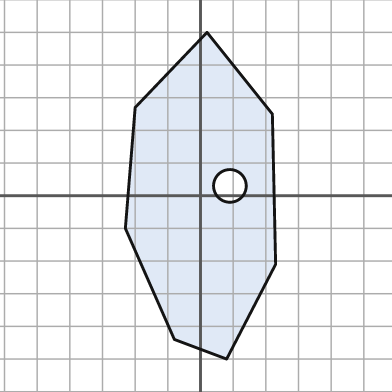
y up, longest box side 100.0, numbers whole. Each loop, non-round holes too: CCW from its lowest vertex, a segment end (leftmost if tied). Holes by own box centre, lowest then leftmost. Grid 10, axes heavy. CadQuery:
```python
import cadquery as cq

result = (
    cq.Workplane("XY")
    .moveTo(8.0, -50.0)
    .lineTo(23.0, -21.0)
    .lineTo(22.0, 25.0)
    .lineTo(2.0, 50.0)
    .lineTo(-20.0, 27.0)
    .lineTo(-23.0, -10.0)
    .lineTo(-8.0, -44.0)
    .close()
    .moveTo(9.0, 3.0)
    .circle(5.0)
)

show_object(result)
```